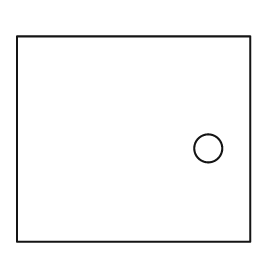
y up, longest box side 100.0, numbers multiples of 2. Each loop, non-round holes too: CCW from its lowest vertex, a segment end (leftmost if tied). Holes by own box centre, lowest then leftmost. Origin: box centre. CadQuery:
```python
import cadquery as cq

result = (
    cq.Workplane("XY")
    .moveTo(-50.0, -44.0)
    .lineTo(50.0, -44.0)
    .lineTo(50.0, 44.0)
    .lineTo(-50.0, 44.0)
    .close()
    .moveTo(32.0, -4.0)
    .circle(6.0)
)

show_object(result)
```